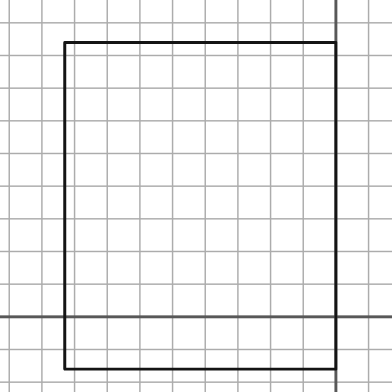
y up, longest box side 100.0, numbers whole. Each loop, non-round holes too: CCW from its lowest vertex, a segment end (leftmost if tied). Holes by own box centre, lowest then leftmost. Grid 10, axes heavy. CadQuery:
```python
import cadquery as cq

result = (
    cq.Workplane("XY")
    .moveTo(-83.0, -16.0)
    .lineTo(0.0, -16.0)
    .lineTo(0.0, 84.0)
    .lineTo(-83.0, 84.0)
    .close()
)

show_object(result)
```